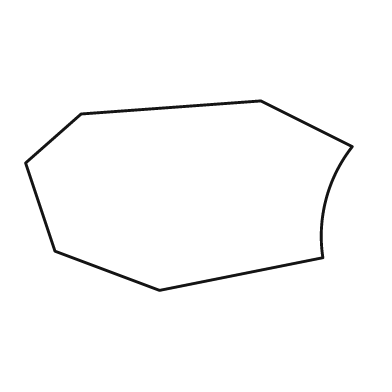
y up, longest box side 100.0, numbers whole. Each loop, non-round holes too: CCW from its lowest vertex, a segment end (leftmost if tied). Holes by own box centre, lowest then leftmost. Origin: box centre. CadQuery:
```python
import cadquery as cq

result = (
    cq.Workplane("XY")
    .moveTo(-9.0, -29.0)
    .lineTo(41.0, -19.0)
    .threePointArc((42.0, -1.0), (50.0, 15.0))
    .lineTo(22.0, 29.0)
    .lineTo(-33.0, 25.0)
    .lineTo(-50.0, 10.0)
    .lineTo(-41.0, -17.0)
    .close()
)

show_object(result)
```